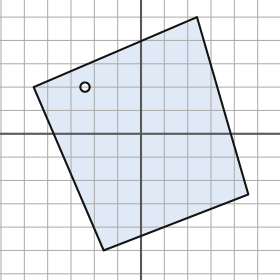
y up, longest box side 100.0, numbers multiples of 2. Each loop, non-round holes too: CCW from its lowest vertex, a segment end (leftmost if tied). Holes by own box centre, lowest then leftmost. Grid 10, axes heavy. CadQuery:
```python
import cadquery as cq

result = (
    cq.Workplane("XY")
    .moveTo(-16.0, -50.0)
    .lineTo(46.0, -26.0)
    .lineTo(24.0, 50.0)
    .lineTo(-46.0, 20.0)
    .close()
    .moveTo(-24.0, 20.0)
    .circle(2.0)
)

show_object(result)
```